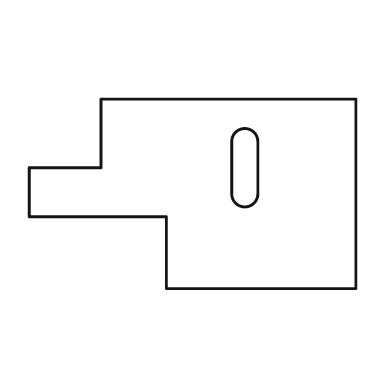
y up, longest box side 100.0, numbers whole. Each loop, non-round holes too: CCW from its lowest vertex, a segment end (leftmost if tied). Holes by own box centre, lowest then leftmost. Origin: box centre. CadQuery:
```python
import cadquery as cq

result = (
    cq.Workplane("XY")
    .moveTo(-8.0, -29.0)
    .lineTo(50.0, -29.0)
    .lineTo(50.0, 29.0)
    .lineTo(-28.0, 29.0)
    .lineTo(-28.0, 8.0)
    .lineTo(-50.0, 8.0)
    .lineTo(-50.0, -7.0)
    .lineTo(-8.0, -7.0)
    .close()
    .moveTo(12.0, 0.0)
    .threePointArc((16.0, -4.0), (20.0, 0.0))
    .lineTo(20.0, 16.0)
    .threePointArc((16.0, 20.0), (12.0, 16.0))
    .close()
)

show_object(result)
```